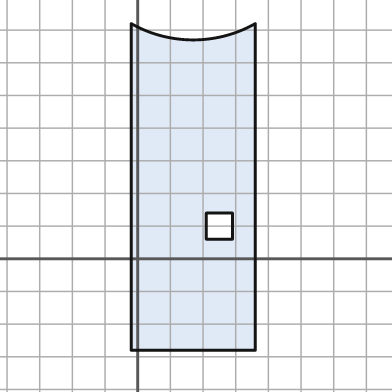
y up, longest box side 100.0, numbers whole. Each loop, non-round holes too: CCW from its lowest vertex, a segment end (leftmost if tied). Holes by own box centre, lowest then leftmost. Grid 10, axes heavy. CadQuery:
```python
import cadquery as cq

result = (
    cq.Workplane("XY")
    .moveTo(-2.0, -28.0)
    .lineTo(36.0, -28.0)
    .lineTo(36.0, 72.0)
    .threePointArc((17.0, 67.0), (-2.0, 72.0))
    .close()
    .moveTo(21.0, 6.0)
    .lineTo(29.0, 6.0)
    .lineTo(29.0, 14.0)
    .lineTo(21.0, 14.0)
    .close()
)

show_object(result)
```